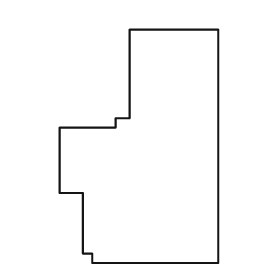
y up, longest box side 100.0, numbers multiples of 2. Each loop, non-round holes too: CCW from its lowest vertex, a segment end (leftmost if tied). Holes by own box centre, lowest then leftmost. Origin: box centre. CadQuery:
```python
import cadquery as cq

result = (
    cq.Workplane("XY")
    .moveTo(-20.0, -50.0)
    .lineTo(34.0, -50.0)
    .lineTo(34.0, 50.0)
    .lineTo(-4.0, 50.0)
    .lineTo(-4.0, 12.0)
    .lineTo(-10.0, 12.0)
    .lineTo(-10.0, 8.0)
    .lineTo(-34.0, 8.0)
    .lineTo(-34.0, -20.0)
    .lineTo(-24.0, -20.0)
    .lineTo(-24.0, -46.0)
    .lineTo(-20.0, -46.0)
    .close()
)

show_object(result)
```